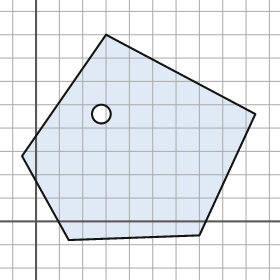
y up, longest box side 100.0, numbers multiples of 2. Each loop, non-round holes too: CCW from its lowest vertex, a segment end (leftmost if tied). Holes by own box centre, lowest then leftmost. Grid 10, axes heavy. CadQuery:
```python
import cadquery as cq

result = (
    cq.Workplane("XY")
    .moveTo(14.0, -8.0)
    .lineTo(70.0, -6.0)
    .lineTo(94.0, 46.0)
    .lineTo(30.0, 80.0)
    .lineTo(-6.0, 28.0)
    .close()
    .moveTo(28.0, 46.0)
    .circle(4.0)
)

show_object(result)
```